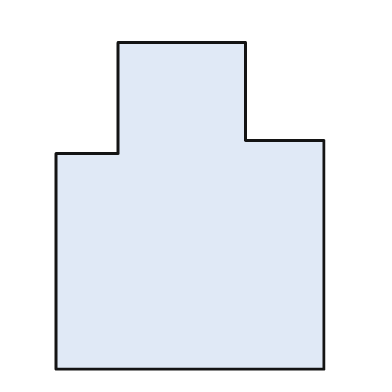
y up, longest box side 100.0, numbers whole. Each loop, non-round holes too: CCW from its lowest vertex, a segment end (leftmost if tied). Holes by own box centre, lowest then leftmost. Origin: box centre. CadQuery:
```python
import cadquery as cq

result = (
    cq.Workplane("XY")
    .moveTo(-41.0, -50.0)
    .lineTo(41.0, -50.0)
    .lineTo(41.0, 20.0)
    .lineTo(17.0, 20.0)
    .lineTo(17.0, 50.0)
    .lineTo(-22.0, 50.0)
    .lineTo(-22.0, 16.0)
    .lineTo(-41.0, 16.0)
    .close()
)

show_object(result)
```